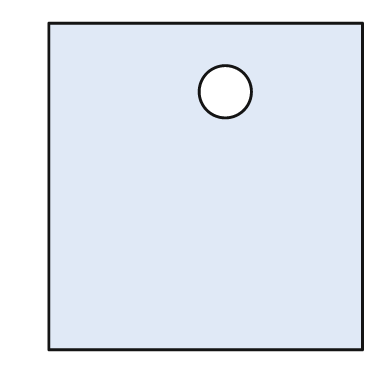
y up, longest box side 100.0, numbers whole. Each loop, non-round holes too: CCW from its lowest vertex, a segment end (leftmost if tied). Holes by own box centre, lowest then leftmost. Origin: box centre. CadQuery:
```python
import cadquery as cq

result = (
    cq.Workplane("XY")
    .moveTo(-48.0, -50.0)
    .lineTo(48.0, -50.0)
    .lineTo(48.0, 50.0)
    .lineTo(-48.0, 50.0)
    .close()
    .moveTo(6.0, 29.0)
    .circle(8.0)
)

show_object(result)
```